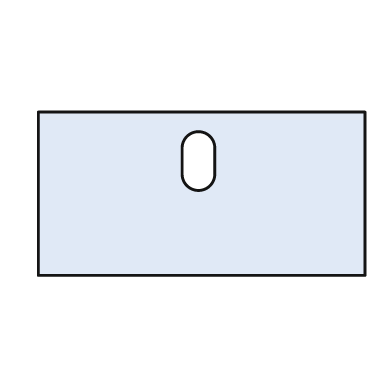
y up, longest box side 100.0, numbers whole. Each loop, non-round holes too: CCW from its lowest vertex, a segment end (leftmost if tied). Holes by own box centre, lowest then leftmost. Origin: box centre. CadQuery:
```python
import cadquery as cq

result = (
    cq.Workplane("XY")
    .moveTo(-50.0, -25.0)
    .lineTo(50.0, -25.0)
    .lineTo(50.0, 25.0)
    .lineTo(-50.0, 25.0)
    .close()
    .moveTo(-6.0, 6.0)
    .threePointArc((-1.0, 1.0), (4.0, 6.0))
    .lineTo(4.0, 14.0)
    .threePointArc((-1.0, 19.0), (-6.0, 14.0))
    .close()
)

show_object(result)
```